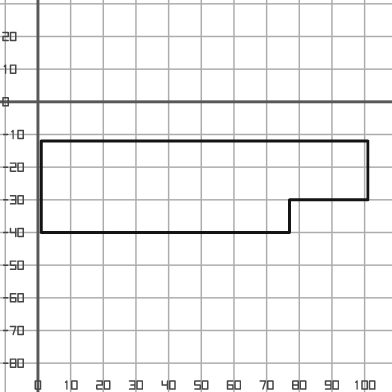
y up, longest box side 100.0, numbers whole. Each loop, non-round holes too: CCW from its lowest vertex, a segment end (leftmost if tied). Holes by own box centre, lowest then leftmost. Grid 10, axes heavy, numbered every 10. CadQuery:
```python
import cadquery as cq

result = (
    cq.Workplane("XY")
    .moveTo(1.0, -40.0)
    .lineTo(77.0, -40.0)
    .lineTo(77.0, -30.0)
    .lineTo(101.0, -30.0)
    .lineTo(101.0, -12.0)
    .lineTo(1.0, -12.0)
    .close()
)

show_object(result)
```